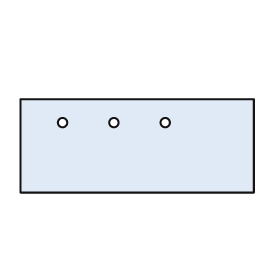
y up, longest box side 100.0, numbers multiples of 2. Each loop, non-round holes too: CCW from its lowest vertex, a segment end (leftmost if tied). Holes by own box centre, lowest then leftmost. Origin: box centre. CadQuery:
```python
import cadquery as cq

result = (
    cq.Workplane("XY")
    .moveTo(-50.0, -20.0)
    .lineTo(50.0, -20.0)
    .lineTo(50.0, 20.0)
    .lineTo(-50.0, 20.0)
    .close()
    .moveTo(-32.0, 10.0)
    .circle(2.0)
    .moveTo(-10.0, 10.0)
    .circle(2.0)
    .moveTo(12.0, 10.0)
    .circle(2.0)
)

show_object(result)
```